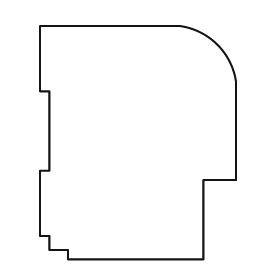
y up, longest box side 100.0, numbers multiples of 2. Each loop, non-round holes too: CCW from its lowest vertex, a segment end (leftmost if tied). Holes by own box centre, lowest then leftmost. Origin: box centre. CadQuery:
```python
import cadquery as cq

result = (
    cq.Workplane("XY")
    .moveTo(-30.0, -50.0)
    .lineTo(28.0, -50.0)
    .lineTo(28.0, -16.0)
    .lineTo(42.0, -16.0)
    .lineTo(42.0, 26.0)
    .threePointArc((34.0, 42.0), (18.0, 50.0))
    .lineTo(-42.0, 50.0)
    .lineTo(-42.0, 22.0)
    .lineTo(-38.0, 22.0)
    .lineTo(-38.0, -12.0)
    .lineTo(-42.0, -12.0)
    .lineTo(-42.0, -40.0)
    .lineTo(-38.0, -40.0)
    .lineTo(-38.0, -46.0)
    .lineTo(-30.0, -46.0)
    .close()
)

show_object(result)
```